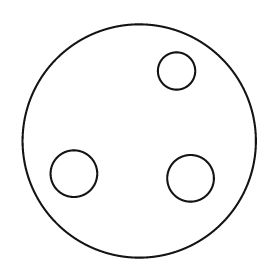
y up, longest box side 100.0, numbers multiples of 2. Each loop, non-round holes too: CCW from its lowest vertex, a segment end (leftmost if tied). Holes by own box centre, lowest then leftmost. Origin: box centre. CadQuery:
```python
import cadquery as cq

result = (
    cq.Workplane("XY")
    .moveTo(0.0, 0.0)
    .circle(50.0)
    .moveTo(22.0, -16.0)
    .circle(10.0)
    .moveTo(-28.0, -14.0)
    .circle(10.0)
    .moveTo(16.0, 30.0)
    .circle(8.0)
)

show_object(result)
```